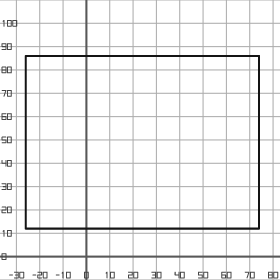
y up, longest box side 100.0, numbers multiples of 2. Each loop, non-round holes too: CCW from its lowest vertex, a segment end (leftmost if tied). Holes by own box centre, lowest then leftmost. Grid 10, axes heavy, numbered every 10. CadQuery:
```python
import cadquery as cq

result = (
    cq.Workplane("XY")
    .moveTo(-26.0, 12.0)
    .lineTo(74.0, 12.0)
    .lineTo(74.0, 86.0)
    .lineTo(-26.0, 86.0)
    .close()
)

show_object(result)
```